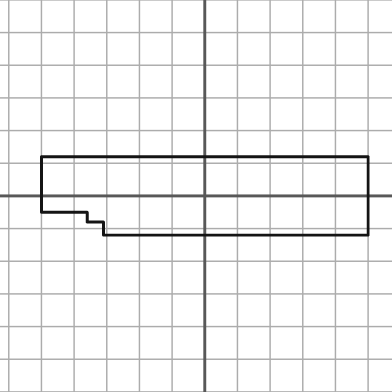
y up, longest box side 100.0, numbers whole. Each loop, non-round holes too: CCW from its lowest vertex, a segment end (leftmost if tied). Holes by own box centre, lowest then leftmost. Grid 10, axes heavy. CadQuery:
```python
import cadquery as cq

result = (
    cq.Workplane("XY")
    .moveTo(-31.0, -12.0)
    .lineTo(50.0, -12.0)
    .lineTo(50.0, 12.0)
    .lineTo(-50.0, 12.0)
    .lineTo(-50.0, -5.0)
    .lineTo(-36.0, -5.0)
    .lineTo(-36.0, -8.0)
    .lineTo(-31.0, -8.0)
    .close()
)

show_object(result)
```